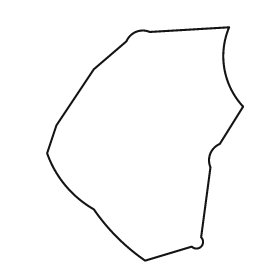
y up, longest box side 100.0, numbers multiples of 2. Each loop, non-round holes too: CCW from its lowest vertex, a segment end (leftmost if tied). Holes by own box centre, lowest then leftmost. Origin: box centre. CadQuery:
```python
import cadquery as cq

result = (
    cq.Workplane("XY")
    .moveTo(0.0, -50.0)
    .lineTo(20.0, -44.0)
    .threePointArc((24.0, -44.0), (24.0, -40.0))
    .lineTo(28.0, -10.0)
    .threePointArc((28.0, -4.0), (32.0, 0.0))
    .lineTo(42.0, 16.0)
    .threePointArc((34.0, 32.0), (36.0, 50.0))
    .lineTo(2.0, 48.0)
    .threePointArc((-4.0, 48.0), (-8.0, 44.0))
    .lineTo(-22.0, 32.0)
    .lineTo(-38.0, 8.0)
    .lineTo(-42.0, -4.0)
    .threePointArc((-34.0, -18.0), (-22.0, -28.0))
    .threePointArc((-12.0, -40.0), (0.0, -50.0))
    .close()
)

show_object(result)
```